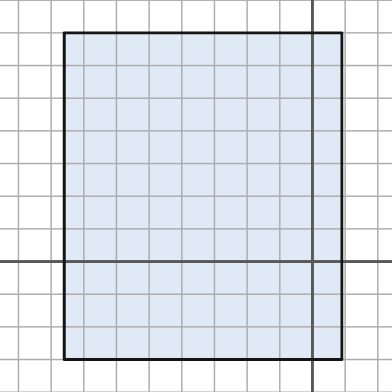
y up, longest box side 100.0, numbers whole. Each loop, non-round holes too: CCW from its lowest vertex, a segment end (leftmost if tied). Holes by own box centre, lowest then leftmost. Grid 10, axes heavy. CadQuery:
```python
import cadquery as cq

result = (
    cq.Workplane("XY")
    .moveTo(-76.0, -30.0)
    .lineTo(9.0, -30.0)
    .lineTo(9.0, 70.0)
    .lineTo(-76.0, 70.0)
    .close()
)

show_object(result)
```